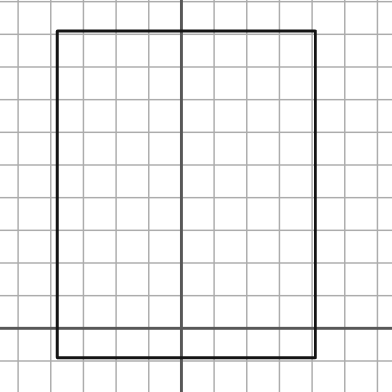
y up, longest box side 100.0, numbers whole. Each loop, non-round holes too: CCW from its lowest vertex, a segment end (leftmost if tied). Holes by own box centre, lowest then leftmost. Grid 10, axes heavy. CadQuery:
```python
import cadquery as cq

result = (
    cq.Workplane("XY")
    .moveTo(-38.0, -9.0)
    .lineTo(41.0, -9.0)
    .lineTo(41.0, 91.0)
    .lineTo(-38.0, 91.0)
    .close()
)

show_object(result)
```